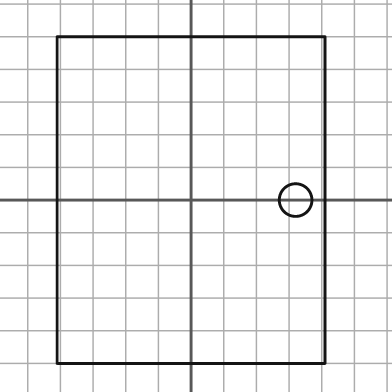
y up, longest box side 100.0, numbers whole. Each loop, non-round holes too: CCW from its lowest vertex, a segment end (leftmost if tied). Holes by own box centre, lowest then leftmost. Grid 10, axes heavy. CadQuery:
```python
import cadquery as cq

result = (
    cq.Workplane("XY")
    .moveTo(-41.0, -50.0)
    .lineTo(41.0, -50.0)
    .lineTo(41.0, 50.0)
    .lineTo(-41.0, 50.0)
    .close()
    .moveTo(32.0, 0.0)
    .circle(5.0)
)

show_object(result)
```